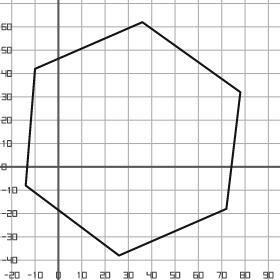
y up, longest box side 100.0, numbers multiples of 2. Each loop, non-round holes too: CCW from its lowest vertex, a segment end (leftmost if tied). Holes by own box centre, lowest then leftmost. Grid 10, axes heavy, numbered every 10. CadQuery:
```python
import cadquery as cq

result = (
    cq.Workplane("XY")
    .moveTo(26.0, -38.0)
    .lineTo(72.0, -18.0)
    .lineTo(78.0, 32.0)
    .lineTo(36.0, 62.0)
    .lineTo(-10.0, 42.0)
    .lineTo(-14.0, -8.0)
    .close()
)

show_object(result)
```